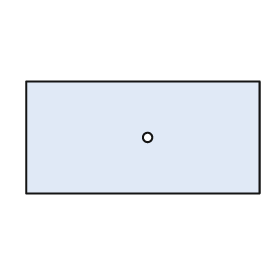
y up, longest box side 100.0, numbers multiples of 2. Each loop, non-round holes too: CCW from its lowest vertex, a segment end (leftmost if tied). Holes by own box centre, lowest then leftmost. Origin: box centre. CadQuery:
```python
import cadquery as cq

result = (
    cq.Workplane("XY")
    .moveTo(-50.0, -24.0)
    .lineTo(50.0, -24.0)
    .lineTo(50.0, 24.0)
    .lineTo(-50.0, 24.0)
    .close()
    .moveTo(2.0, 0.0)
    .circle(2.0)
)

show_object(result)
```